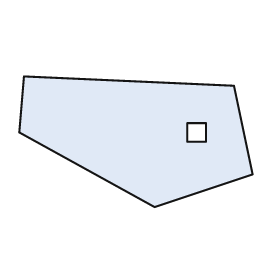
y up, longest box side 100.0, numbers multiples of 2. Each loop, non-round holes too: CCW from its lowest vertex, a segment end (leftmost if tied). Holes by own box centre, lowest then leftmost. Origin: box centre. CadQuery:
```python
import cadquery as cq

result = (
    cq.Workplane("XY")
    .moveTo(8.0, -28.0)
    .lineTo(50.0, -14.0)
    .lineTo(42.0, 24.0)
    .lineTo(-48.0, 28.0)
    .lineTo(-50.0, 4.0)
    .close()
    .moveTo(22.0, 0.0)
    .lineTo(30.0, 0.0)
    .lineTo(30.0, 8.0)
    .lineTo(22.0, 8.0)
    .close()
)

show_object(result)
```